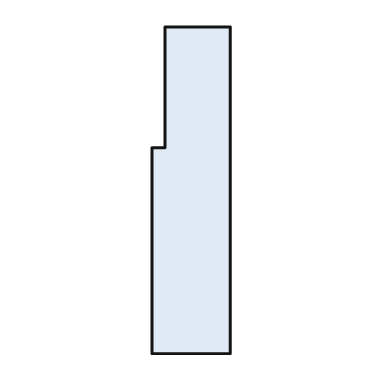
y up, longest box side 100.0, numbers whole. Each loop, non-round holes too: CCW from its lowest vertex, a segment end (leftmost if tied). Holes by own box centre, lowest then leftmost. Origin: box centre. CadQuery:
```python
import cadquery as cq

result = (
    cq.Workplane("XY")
    .moveTo(-12.0, -50.0)
    .lineTo(12.0, -50.0)
    .lineTo(12.0, 50.0)
    .lineTo(-8.0, 50.0)
    .lineTo(-8.0, 13.0)
    .lineTo(-12.0, 13.0)
    .close()
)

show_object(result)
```